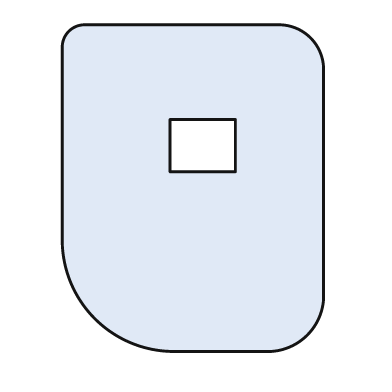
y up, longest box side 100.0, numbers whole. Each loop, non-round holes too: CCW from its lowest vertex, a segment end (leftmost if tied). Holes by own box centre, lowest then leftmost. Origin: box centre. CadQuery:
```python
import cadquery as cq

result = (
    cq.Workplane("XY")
    .moveTo(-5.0, -50.0)
    .lineTo(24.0, -50.0)
    .threePointArc((35.0, -45.0), (40.0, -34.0))
    .lineTo(40.0, 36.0)
    .threePointArc((36.0, 46.0), (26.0, 50.0))
    .lineTo(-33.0, 50.0)
    .threePointArc((-38.0, 48.0), (-40.0, 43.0))
    .lineTo(-40.0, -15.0)
    .threePointArc((-30.0, -40.0), (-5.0, -50.0))
    .close()
    .moveTo(-7.0, 5.0)
    .lineTo(13.0, 5.0)
    .lineTo(13.0, 21.0)
    .lineTo(-7.0, 21.0)
    .close()
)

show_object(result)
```